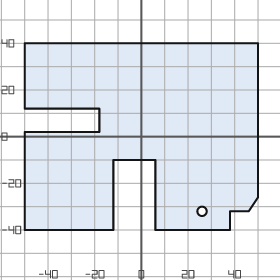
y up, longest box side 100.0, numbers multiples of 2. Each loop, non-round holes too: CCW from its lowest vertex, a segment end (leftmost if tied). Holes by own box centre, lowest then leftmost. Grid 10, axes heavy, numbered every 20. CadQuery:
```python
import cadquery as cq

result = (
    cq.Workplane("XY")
    .moveTo(-50.0, -40.0)
    .lineTo(-12.0, -40.0)
    .lineTo(-12.0, -10.0)
    .lineTo(6.0, -10.0)
    .lineTo(6.0, -40.0)
    .lineTo(38.0, -40.0)
    .lineTo(38.0, -32.0)
    .lineTo(46.0, -32.0)
    .lineTo(50.0, -26.0)
    .lineTo(50.0, 40.0)
    .lineTo(-50.0, 40.0)
    .lineTo(-50.0, 12.0)
    .lineTo(-18.0, 12.0)
    .lineTo(-18.0, 2.0)
    .lineTo(-50.0, 2.0)
    .close()
    .moveTo(26.0, -32.0)
    .circle(2.0)
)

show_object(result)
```